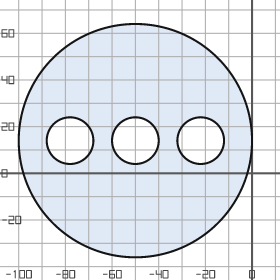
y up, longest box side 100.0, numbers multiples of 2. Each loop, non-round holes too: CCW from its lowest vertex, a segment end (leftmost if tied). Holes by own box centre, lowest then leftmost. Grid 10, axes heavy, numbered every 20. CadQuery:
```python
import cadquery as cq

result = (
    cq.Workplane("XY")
    .moveTo(-50.0, 14.0)
    .circle(50.0)
    .moveTo(-78.0, 14.0)
    .circle(10.0)
    .moveTo(-50.0, 14.0)
    .circle(10.0)
    .moveTo(-22.0, 14.0)
    .circle(10.0)
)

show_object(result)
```